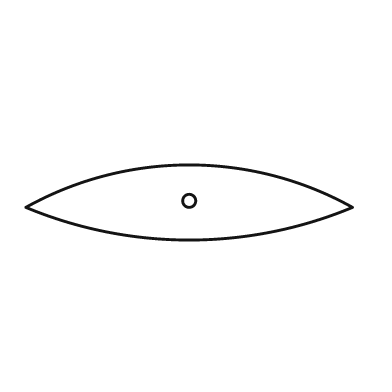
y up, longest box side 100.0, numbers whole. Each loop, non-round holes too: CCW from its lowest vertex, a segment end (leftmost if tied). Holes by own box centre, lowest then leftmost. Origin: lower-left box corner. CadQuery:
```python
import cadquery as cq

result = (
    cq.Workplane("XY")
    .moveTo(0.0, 10.0)
    .threePointArc((50.0, 0.0), (100.0, 10.0))
    .threePointArc((50.0, 23.0), (0.0, 10.0))
    .close()
    .moveTo(50.0, 12.0)
    .circle(2.0)
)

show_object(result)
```